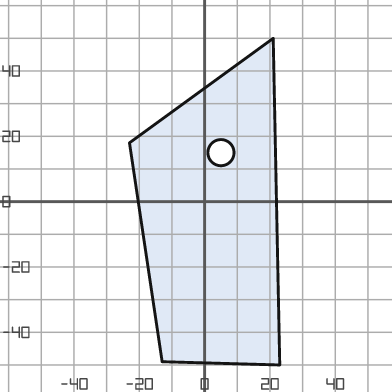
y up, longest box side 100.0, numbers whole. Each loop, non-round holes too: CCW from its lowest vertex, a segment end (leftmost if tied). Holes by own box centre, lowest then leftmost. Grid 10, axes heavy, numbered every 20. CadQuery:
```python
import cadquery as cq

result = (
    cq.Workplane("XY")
    .moveTo(23.0, -50.0)
    .lineTo(21.0, 50.0)
    .lineTo(-23.0, 18.0)
    .lineTo(-13.0, -49.0)
    .close()
    .moveTo(5.0, 15.0)
    .circle(4.0)
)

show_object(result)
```